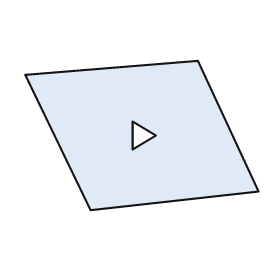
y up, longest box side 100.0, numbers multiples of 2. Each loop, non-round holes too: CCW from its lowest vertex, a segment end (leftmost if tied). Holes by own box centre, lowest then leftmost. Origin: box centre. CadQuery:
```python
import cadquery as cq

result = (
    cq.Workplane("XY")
    .moveTo(-22.0, -32.0)
    .lineTo(50.0, -24.0)
    .lineTo(24.0, 32.0)
    .lineTo(-50.0, 26.0)
    .close()
    .moveTo(-4.0, -6.0)
    .lineTo(6.0, 0.0)
    .lineTo(-4.0, 6.0)
    .close()
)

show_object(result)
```